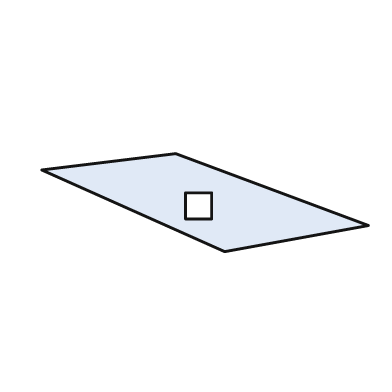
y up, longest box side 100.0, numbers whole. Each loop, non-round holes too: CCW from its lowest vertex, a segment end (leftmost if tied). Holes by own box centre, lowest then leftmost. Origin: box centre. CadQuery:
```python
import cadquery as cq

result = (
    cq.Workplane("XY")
    .moveTo(6.0, -15.0)
    .lineTo(50.0, -7.0)
    .lineTo(-9.0, 15.0)
    .lineTo(-50.0, 10.0)
    .close()
    .moveTo(-6.0, -5.0)
    .lineTo(2.0, -5.0)
    .lineTo(2.0, 3.0)
    .lineTo(-6.0, 3.0)
    .close()
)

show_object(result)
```